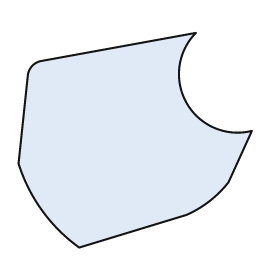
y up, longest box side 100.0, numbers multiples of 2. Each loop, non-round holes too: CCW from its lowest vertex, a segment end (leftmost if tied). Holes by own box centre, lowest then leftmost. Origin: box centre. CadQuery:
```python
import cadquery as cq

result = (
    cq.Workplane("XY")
    .moveTo(-24.0, -46.0)
    .lineTo(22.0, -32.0)
    .threePointArc((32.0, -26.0), (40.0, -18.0))
    .lineTo(50.0, 4.0)
    .threePointArc((22.0, 16.0), (26.0, 46.0))
    .lineTo(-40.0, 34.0)
    .threePointArc((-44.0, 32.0), (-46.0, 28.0))
    .lineTo(-50.0, -10.0)
    .threePointArc((-40.0, -30.0), (-24.0, -46.0))
    .close()
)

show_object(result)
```